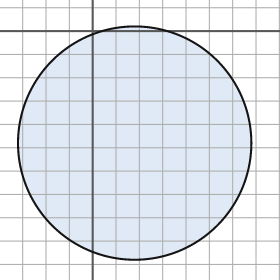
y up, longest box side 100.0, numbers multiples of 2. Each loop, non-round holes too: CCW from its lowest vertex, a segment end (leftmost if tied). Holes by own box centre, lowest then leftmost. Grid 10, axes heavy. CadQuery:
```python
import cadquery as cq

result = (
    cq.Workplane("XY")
    .moveTo(18.0, -48.0)
    .circle(50.0)
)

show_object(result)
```